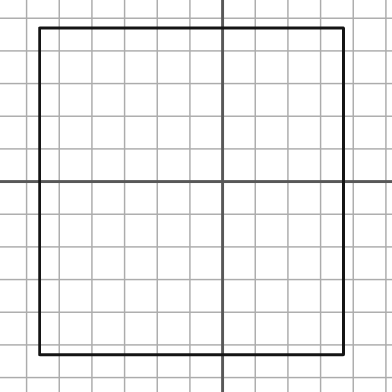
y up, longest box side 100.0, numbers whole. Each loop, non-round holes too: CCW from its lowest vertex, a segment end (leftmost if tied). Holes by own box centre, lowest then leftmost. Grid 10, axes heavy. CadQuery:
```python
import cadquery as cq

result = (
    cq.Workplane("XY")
    .moveTo(-56.0, -53.0)
    .lineTo(37.0, -53.0)
    .lineTo(37.0, 47.0)
    .lineTo(-56.0, 47.0)
    .close()
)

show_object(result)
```